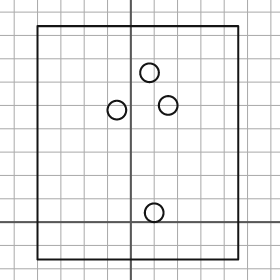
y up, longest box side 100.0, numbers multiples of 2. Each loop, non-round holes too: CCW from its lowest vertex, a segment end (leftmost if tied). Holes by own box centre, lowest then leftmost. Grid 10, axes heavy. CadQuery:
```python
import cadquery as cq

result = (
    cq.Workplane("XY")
    .moveTo(-40.0, -16.0)
    .lineTo(46.0, -16.0)
    .lineTo(46.0, 84.0)
    .lineTo(-40.0, 84.0)
    .close()
    .moveTo(10.0, 4.0)
    .circle(4.0)
    .moveTo(-6.0, 48.0)
    .circle(4.0)
    .moveTo(16.0, 50.0)
    .circle(4.0)
    .moveTo(8.0, 64.0)
    .circle(4.0)
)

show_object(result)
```